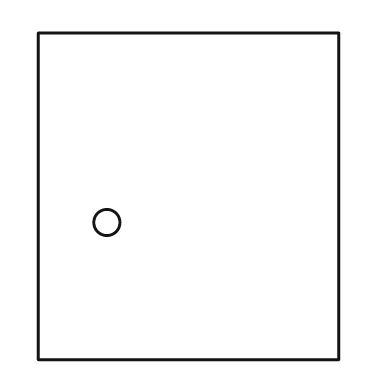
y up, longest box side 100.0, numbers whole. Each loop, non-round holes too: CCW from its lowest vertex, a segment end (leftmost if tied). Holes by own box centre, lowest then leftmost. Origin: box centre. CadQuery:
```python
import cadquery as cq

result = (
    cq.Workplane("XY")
    .moveTo(-46.0, -50.0)
    .lineTo(46.0, -50.0)
    .lineTo(46.0, 50.0)
    .lineTo(-46.0, 50.0)
    .close()
    .moveTo(-25.0, -8.0)
    .circle(4.0)
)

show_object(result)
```